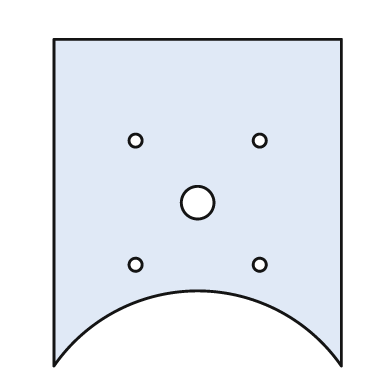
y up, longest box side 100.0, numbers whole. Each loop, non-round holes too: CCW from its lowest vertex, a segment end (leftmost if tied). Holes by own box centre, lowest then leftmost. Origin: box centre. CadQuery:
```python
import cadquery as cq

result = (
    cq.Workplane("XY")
    .moveTo(-44.0, -50.0)
    .threePointArc((0.0, -27.0), (44.0, -50.0))
    .lineTo(44.0, 50.0)
    .lineTo(-44.0, 50.0)
    .close()
    .moveTo(-19.0, -19.0)
    .circle(2.0)
    .moveTo(19.0, -19.0)
    .circle(2.0)
    .moveTo(0.0, 0.0)
    .circle(5.0)
    .moveTo(-19.0, 19.0)
    .circle(2.0)
    .moveTo(19.0, 19.0)
    .circle(2.0)
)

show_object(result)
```